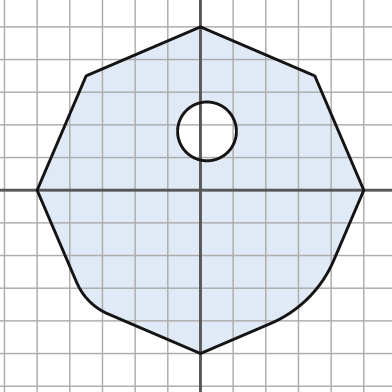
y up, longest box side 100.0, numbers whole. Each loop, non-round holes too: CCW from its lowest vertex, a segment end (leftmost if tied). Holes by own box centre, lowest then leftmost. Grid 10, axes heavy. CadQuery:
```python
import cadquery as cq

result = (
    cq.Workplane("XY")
    .moveTo(0.0, -50.0)
    .lineTo(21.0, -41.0)
    .threePointArc((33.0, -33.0), (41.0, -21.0))
    .lineTo(50.0, 0.0)
    .lineTo(35.0, 35.0)
    .lineTo(0.0, 50.0)
    .lineTo(-35.0, 35.0)
    .lineTo(-50.0, 0.0)
    .lineTo(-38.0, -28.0)
    .threePointArc((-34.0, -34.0), (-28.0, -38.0))
    .close()
    .moveTo(2.0, 18.0)
    .circle(9.0)
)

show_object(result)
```